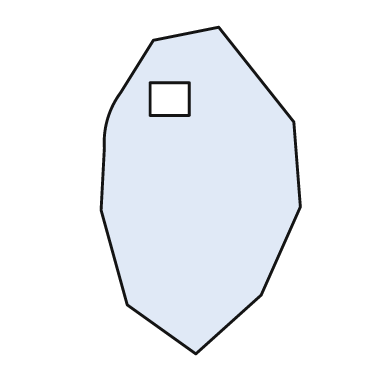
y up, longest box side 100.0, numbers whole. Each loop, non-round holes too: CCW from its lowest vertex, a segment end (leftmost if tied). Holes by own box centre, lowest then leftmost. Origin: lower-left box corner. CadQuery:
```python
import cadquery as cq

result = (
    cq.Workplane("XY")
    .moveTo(29.0, 0.0)
    .lineTo(49.0, 18.0)
    .lineTo(61.0, 45.0)
    .lineTo(59.0, 71.0)
    .lineTo(36.0, 100.0)
    .lineTo(16.0, 96.0)
    .lineTo(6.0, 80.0)
    .threePointArc((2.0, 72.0), (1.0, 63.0))
    .lineTo(0.0, 44.0)
    .lineTo(8.0, 15.0)
    .close()
    .moveTo(15.0, 73.0)
    .lineTo(27.0, 73.0)
    .lineTo(27.0, 83.0)
    .lineTo(15.0, 83.0)
    .close()
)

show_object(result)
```